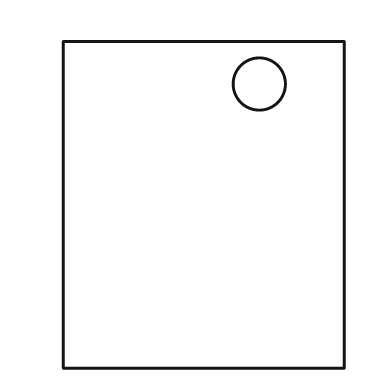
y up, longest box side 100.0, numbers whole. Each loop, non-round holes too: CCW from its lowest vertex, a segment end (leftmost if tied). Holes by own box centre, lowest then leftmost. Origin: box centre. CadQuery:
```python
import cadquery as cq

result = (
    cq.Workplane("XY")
    .moveTo(-43.0, -50.0)
    .lineTo(43.0, -50.0)
    .lineTo(43.0, 50.0)
    .lineTo(-43.0, 50.0)
    .close()
    .moveTo(17.0, 37.0)
    .circle(8.0)
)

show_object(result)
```